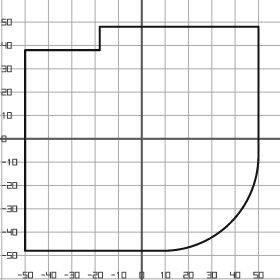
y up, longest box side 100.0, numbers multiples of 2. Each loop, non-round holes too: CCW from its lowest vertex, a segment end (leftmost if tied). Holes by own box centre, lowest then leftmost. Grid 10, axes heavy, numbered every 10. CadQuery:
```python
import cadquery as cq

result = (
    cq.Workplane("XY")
    .moveTo(-50.0, -48.0)
    .lineTo(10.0, -48.0)
    .threePointArc((38.0, -36.0), (50.0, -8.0))
    .lineTo(50.0, 48.0)
    .lineTo(-18.0, 48.0)
    .lineTo(-18.0, 38.0)
    .lineTo(-50.0, 38.0)
    .close()
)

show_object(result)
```